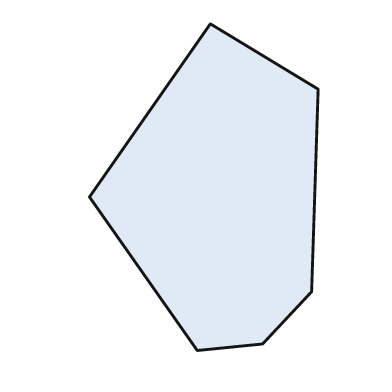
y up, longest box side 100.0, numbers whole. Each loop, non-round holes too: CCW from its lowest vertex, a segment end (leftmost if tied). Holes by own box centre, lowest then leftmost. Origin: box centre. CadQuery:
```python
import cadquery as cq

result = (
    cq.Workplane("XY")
    .moveTo(-2.0, -50.0)
    .lineTo(18.0, -48.0)
    .lineTo(33.0, -32.0)
    .lineTo(35.0, 30.0)
    .lineTo(2.0, 50.0)
    .lineTo(-35.0, -3.0)
    .close()
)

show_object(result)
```